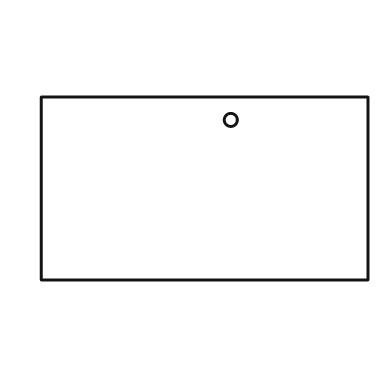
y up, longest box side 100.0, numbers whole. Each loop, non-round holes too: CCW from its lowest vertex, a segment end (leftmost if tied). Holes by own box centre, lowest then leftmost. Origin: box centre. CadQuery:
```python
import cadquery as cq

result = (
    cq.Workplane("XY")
    .moveTo(-50.0, -28.0)
    .lineTo(50.0, -28.0)
    .lineTo(50.0, 28.0)
    .lineTo(-50.0, 28.0)
    .close()
    .moveTo(8.0, 21.0)
    .circle(2.0)
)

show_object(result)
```